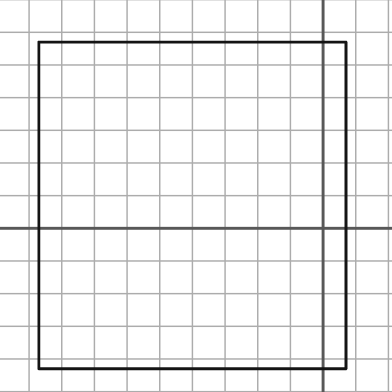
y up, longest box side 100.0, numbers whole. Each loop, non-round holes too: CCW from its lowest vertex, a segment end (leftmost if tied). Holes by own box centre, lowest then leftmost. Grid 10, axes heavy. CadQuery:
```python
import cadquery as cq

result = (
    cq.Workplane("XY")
    .moveTo(-87.0, -43.0)
    .lineTo(7.0, -43.0)
    .lineTo(7.0, 57.0)
    .lineTo(-87.0, 57.0)
    .close()
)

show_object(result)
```